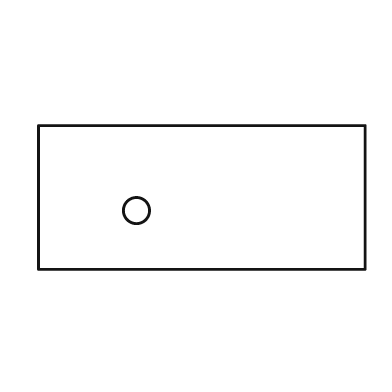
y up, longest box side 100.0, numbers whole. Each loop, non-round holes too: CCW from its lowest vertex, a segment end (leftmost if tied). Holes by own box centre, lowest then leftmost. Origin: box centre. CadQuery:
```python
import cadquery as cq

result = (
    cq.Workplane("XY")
    .moveTo(-50.0, -22.0)
    .lineTo(50.0, -22.0)
    .lineTo(50.0, 22.0)
    .lineTo(-50.0, 22.0)
    .close()
    .moveTo(-20.0, -4.0)
    .circle(4.0)
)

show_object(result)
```